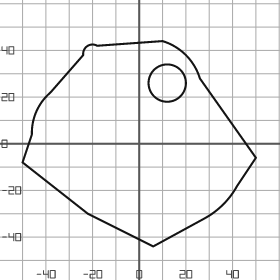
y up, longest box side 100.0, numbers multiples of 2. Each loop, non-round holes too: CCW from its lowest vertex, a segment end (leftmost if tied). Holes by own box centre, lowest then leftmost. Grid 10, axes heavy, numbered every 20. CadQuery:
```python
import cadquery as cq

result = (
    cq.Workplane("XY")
    .moveTo(6.0, -44.0)
    .lineTo(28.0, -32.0)
    .threePointArc((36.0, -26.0), (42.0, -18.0))
    .lineTo(50.0, -6.0)
    .lineTo(26.0, 28.0)
    .threePointArc((20.0, 38.0), (10.0, 44.0))
    .lineTo(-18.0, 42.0)
    .threePointArc((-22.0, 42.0), (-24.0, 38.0))
    .lineTo(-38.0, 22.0)
    .threePointArc((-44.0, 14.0), (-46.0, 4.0))
    .lineTo(-50.0, -8.0)
    .lineTo(-22.0, -30.0)
    .close()
    .moveTo(12.0, 26.0)
    .circle(8.0)
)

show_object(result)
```